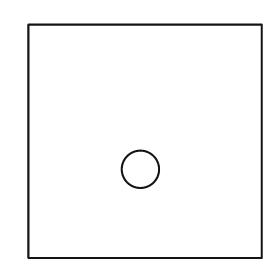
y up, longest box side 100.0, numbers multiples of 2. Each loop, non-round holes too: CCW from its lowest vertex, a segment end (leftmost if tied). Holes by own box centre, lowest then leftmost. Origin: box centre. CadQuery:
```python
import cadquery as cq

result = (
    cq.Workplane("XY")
    .moveTo(-50.0, -50.0)
    .lineTo(50.0, -50.0)
    .lineTo(50.0, 50.0)
    .lineTo(-50.0, 50.0)
    .close()
    .moveTo(-2.0, -12.0)
    .circle(8.0)
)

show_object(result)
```